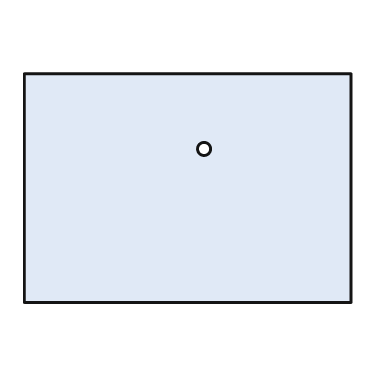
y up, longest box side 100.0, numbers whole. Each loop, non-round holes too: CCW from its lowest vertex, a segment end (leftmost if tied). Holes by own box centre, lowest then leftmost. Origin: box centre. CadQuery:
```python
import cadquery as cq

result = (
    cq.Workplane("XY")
    .moveTo(-50.0, -35.0)
    .lineTo(50.0, -35.0)
    .lineTo(50.0, 35.0)
    .lineTo(-50.0, 35.0)
    .close()
    .moveTo(5.0, 12.0)
    .circle(2.0)
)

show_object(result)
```